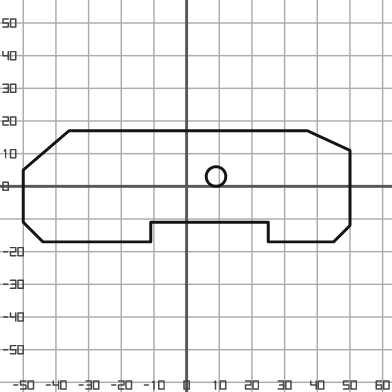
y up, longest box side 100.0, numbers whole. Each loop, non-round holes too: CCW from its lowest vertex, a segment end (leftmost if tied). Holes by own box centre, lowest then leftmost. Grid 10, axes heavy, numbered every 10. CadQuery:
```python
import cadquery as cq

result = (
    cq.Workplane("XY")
    .moveTo(-44.0, -17.0)
    .lineTo(-11.0, -17.0)
    .lineTo(-11.0, -11.0)
    .lineTo(25.0, -11.0)
    .lineTo(25.0, -17.0)
    .lineTo(45.0, -17.0)
    .lineTo(50.0, -12.0)
    .lineTo(50.0, 11.0)
    .lineTo(37.0, 17.0)
    .lineTo(-36.0, 17.0)
    .lineTo(-50.0, 5.0)
    .lineTo(-50.0, -11.0)
    .close()
    .moveTo(9.0, 3.0)
    .circle(3.0)
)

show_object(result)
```